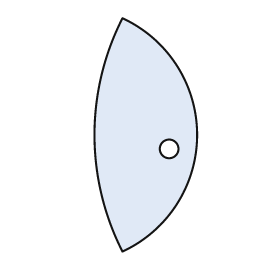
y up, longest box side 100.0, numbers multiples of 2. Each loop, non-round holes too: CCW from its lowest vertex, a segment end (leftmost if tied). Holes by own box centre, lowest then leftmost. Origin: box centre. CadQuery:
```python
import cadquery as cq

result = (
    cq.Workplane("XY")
    .moveTo(-10.0, -50.0)
    .threePointArc((22.0, 0.0), (-10.0, 50.0))
    .threePointArc((-22.0, 0.0), (-10.0, -50.0))
    .close()
    .moveTo(10.0, -6.0)
    .circle(4.0)
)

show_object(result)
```